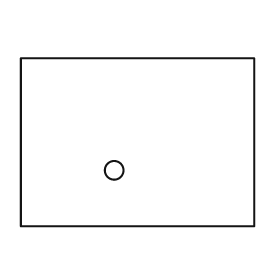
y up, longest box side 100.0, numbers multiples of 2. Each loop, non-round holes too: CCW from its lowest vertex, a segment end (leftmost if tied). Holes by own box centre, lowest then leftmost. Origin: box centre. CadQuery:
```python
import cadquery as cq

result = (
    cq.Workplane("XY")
    .moveTo(-50.0, -36.0)
    .lineTo(50.0, -36.0)
    .lineTo(50.0, 36.0)
    .lineTo(-50.0, 36.0)
    .close()
    .moveTo(-10.0, -12.0)
    .circle(4.0)
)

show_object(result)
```